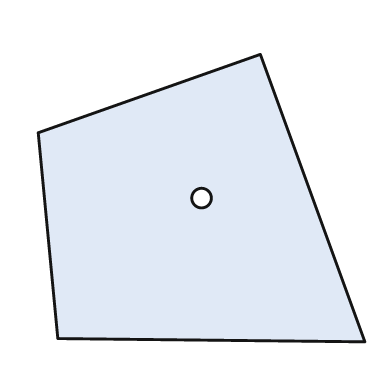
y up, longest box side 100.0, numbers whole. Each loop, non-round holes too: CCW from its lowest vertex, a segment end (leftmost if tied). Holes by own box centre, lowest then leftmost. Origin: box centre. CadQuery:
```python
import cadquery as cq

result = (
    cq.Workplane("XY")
    .moveTo(50.0, -44.0)
    .lineTo(18.0, 44.0)
    .lineTo(-50.0, 20.0)
    .lineTo(-44.0, -43.0)
    .close()
    .moveTo(0.0, 0.0)
    .circle(3.0)
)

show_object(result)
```